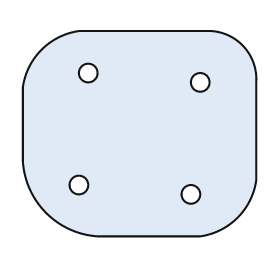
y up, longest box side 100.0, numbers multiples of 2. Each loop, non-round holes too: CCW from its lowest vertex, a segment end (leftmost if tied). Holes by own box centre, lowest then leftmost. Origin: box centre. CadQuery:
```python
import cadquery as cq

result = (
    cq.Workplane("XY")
    .moveTo(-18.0, -44.0)
    .lineTo(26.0, -44.0)
    .threePointArc((42.0, -36.0), (50.0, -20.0))
    .lineTo(50.0, 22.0)
    .threePointArc((44.0, 38.0), (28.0, 44.0))
    .lineTo(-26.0, 44.0)
    .threePointArc((-42.0, 36.0), (-50.0, 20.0))
    .lineTo(-50.0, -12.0)
    .threePointArc((-40.0, -34.0), (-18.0, -44.0))
    .close()
    .moveTo(22.0, -26.0)
    .circle(4.0)
    .moveTo(-26.0, -22.0)
    .circle(4.0)
    .moveTo(26.0, 22.0)
    .circle(4.0)
    .moveTo(-22.0, 26.0)
    .circle(4.0)
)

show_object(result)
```